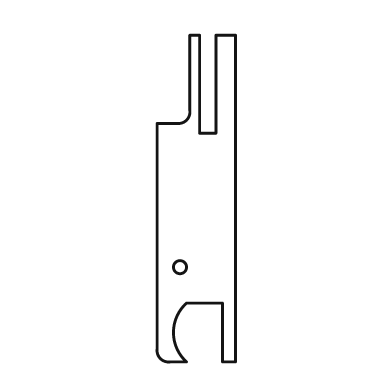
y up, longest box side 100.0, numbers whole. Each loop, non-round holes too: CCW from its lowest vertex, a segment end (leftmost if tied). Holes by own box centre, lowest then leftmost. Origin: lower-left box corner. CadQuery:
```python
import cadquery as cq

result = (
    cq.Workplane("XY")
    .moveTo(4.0, 0.0)
    .lineTo(9.0, 0.0)
    .threePointArc((5.0, 9.0), (9.0, 18.0))
    .lineTo(20.0, 18.0)
    .lineTo(20.0, 0.0)
    .lineTo(24.0, 0.0)
    .lineTo(24.0, 100.0)
    .lineTo(18.0, 100.0)
    .lineTo(18.0, 70.0)
    .lineTo(13.0, 70.0)
    .lineTo(13.0, 100.0)
    .lineTo(10.0, 100.0)
    .lineTo(10.0, 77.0)
    .threePointArc((9.0, 74.0), (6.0, 73.0))
    .lineTo(0.0, 73.0)
    .lineTo(0.0, 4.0)
    .threePointArc((1.0, 1.0), (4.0, 0.0))
    .close()
    .moveTo(7.0, 29.0)
    .circle(2.0)
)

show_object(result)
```